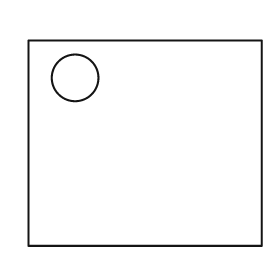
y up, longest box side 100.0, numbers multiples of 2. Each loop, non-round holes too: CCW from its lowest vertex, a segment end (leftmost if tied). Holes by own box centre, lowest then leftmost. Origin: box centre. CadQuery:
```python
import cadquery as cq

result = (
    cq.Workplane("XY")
    .moveTo(-50.0, -44.0)
    .lineTo(50.0, -44.0)
    .lineTo(50.0, 44.0)
    .lineTo(-50.0, 44.0)
    .close()
    .moveTo(-30.0, 28.0)
    .circle(10.0)
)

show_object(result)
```